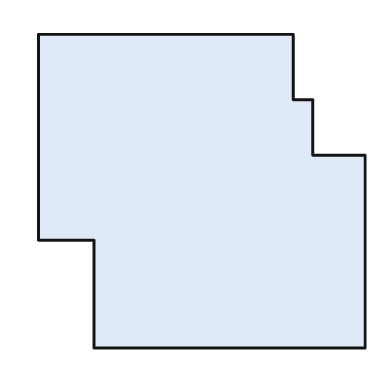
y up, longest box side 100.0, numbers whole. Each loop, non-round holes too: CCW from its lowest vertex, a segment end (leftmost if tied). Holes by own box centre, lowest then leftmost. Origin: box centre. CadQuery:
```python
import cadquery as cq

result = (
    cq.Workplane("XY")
    .moveTo(-33.0, -48.0)
    .lineTo(50.0, -48.0)
    .lineTo(50.0, 11.0)
    .lineTo(34.0, 11.0)
    .lineTo(34.0, 28.0)
    .lineTo(28.0, 28.0)
    .lineTo(28.0, 48.0)
    .lineTo(-50.0, 48.0)
    .lineTo(-50.0, -15.0)
    .lineTo(-33.0, -15.0)
    .close()
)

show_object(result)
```